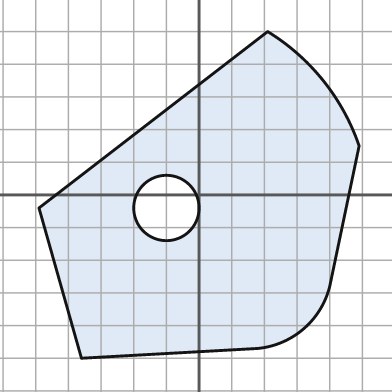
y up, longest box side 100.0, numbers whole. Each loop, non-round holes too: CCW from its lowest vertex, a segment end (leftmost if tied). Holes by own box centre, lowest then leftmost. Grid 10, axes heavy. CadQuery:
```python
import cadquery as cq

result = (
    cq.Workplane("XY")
    .moveTo(-36.0, -50.0)
    .lineTo(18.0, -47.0)
    .threePointArc((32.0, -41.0), (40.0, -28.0))
    .lineTo(49.0, 15.0)
    .threePointArc((38.0, 35.0), (21.0, 50.0))
    .lineTo(-49.0, -4.0)
    .close()
    .moveTo(-10.0, -4.0)
    .circle(10.0)
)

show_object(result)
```